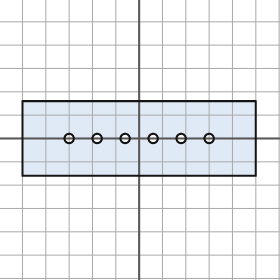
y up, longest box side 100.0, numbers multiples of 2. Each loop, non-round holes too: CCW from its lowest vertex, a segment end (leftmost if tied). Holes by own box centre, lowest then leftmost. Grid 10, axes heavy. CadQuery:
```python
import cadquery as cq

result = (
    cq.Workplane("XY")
    .moveTo(-50.0, -16.0)
    .lineTo(50.0, -16.0)
    .lineTo(50.0, 16.0)
    .lineTo(-50.0, 16.0)
    .close()
    .moveTo(-30.0, 0.0)
    .circle(2.0)
    .moveTo(-18.0, 0.0)
    .circle(2.0)
    .moveTo(-6.0, 0.0)
    .circle(2.0)
    .moveTo(6.0, 0.0)
    .circle(2.0)
    .moveTo(18.0, 0.0)
    .circle(2.0)
    .moveTo(30.0, 0.0)
    .circle(2.0)
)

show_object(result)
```